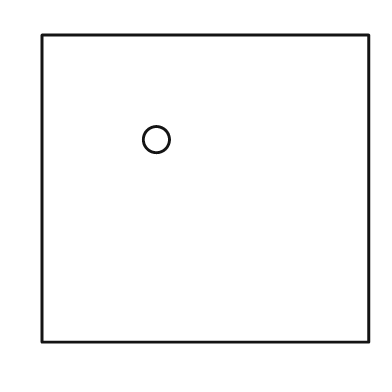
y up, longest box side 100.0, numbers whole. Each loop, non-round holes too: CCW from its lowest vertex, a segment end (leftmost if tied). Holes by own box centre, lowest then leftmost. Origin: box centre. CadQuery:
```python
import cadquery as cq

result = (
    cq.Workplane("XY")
    .moveTo(-50.0, -47.0)
    .lineTo(50.0, -47.0)
    .lineTo(50.0, 47.0)
    .lineTo(-50.0, 47.0)
    .close()
    .moveTo(-15.0, 15.0)
    .circle(4.0)
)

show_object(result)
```